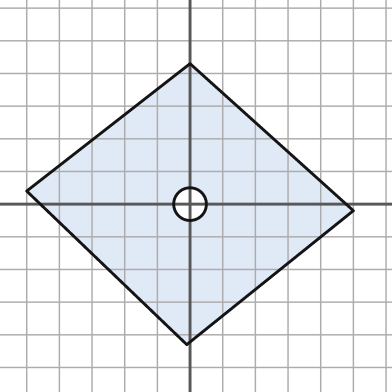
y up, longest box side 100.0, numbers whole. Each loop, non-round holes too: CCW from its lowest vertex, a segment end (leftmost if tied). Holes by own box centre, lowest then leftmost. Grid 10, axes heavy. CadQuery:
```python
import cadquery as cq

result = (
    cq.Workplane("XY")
    .moveTo(-1.0, -43.0)
    .lineTo(50.0, -2.0)
    .lineTo(0.0, 43.0)
    .lineTo(-50.0, 4.0)
    .close()
    .moveTo(0.0, 0.0)
    .circle(5.0)
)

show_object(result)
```